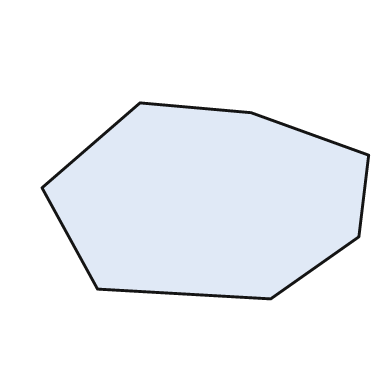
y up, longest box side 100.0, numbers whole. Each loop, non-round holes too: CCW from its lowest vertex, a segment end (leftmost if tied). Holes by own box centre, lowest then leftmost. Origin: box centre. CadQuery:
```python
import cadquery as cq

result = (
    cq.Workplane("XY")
    .moveTo(20.0, -30.0)
    .lineTo(47.0, -11.0)
    .lineTo(50.0, 14.0)
    .lineTo(14.0, 27.0)
    .lineTo(-20.0, 30.0)
    .lineTo(-50.0, 4.0)
    .lineTo(-33.0, -27.0)
    .close()
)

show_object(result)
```